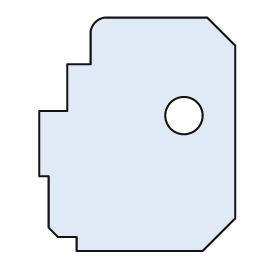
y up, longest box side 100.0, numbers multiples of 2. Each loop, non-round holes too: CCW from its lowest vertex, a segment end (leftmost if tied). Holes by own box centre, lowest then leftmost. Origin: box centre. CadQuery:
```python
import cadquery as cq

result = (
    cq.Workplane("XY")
    .moveTo(-26.0, -50.0)
    .lineTo(28.0, -50.0)
    .lineTo(42.0, -36.0)
    .lineTo(42.0, 38.0)
    .lineTo(30.0, 50.0)
    .lineTo(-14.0, 50.0)
    .threePointArc((-18.0, 48.0), (-20.0, 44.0))
    .lineTo(-20.0, 30.0)
    .lineTo(-30.0, 30.0)
    .lineTo(-30.0, 10.0)
    .lineTo(-42.0, 10.0)
    .lineTo(-42.0, -18.0)
    .lineTo(-38.0, -18.0)
    .lineTo(-38.0, -40.0)
    .lineTo(-34.0, -44.0)
    .lineTo(-26.0, -44.0)
    .close()
    .moveTo(20.0, 8.0)
    .circle(8.0)
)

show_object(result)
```